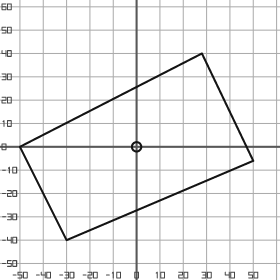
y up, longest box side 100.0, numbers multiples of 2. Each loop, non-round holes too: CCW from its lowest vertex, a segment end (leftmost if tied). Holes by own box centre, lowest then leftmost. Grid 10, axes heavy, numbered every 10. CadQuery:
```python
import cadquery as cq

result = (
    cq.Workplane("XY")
    .moveTo(-30.0, -40.0)
    .lineTo(50.0, -6.0)
    .lineTo(28.0, 40.0)
    .lineTo(-50.0, 0.0)
    .close()
    .moveTo(0.0, 0.0)
    .circle(2.0)
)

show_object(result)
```